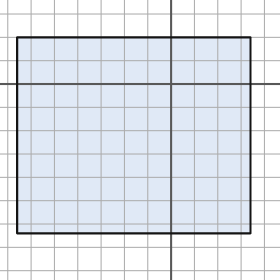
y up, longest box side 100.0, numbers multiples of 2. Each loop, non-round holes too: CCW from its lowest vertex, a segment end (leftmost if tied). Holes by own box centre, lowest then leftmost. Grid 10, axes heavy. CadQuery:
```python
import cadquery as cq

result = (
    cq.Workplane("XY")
    .moveTo(-66.0, -64.0)
    .lineTo(34.0, -64.0)
    .lineTo(34.0, 20.0)
    .lineTo(-66.0, 20.0)
    .close()
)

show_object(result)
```